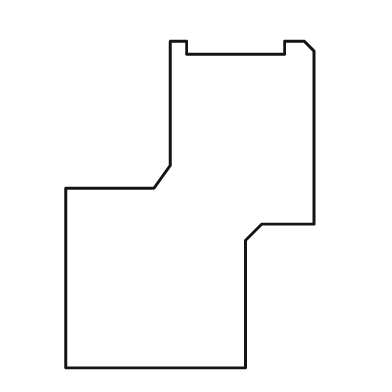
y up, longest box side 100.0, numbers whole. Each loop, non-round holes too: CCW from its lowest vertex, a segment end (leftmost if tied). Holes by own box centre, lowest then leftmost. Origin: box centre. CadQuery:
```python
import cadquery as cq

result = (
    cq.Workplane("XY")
    .moveTo(-38.0, -50.0)
    .lineTo(17.0, -50.0)
    .lineTo(17.0, -11.0)
    .lineTo(22.0, -6.0)
    .lineTo(38.0, -6.0)
    .lineTo(38.0, 47.0)
    .lineTo(35.0, 50.0)
    .lineTo(29.0, 50.0)
    .lineTo(29.0, 46.0)
    .lineTo(-1.0, 46.0)
    .lineTo(-1.0, 50.0)
    .lineTo(-6.0, 50.0)
    .lineTo(-6.0, 12.0)
    .lineTo(-11.0, 5.0)
    .lineTo(-38.0, 5.0)
    .close()
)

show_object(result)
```